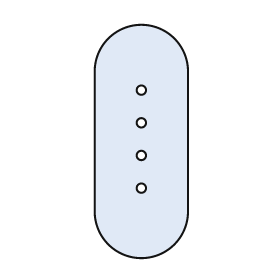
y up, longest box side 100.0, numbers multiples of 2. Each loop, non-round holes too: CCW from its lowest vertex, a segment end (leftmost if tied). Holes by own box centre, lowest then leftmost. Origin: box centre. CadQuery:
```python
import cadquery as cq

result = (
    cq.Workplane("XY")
    .moveTo(-20.0, -30.0)
    .threePointArc((0.0, -50.0), (20.0, -30.0))
    .lineTo(20.0, 30.0)
    .threePointArc((0.0, 50.0), (-20.0, 30.0))
    .close()
    .moveTo(0.0, -20.0)
    .circle(2.0)
    .moveTo(0.0, -6.0)
    .circle(2.0)
    .moveTo(0.0, 8.0)
    .circle(2.0)
    .moveTo(0.0, 22.0)
    .circle(2.0)
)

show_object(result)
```